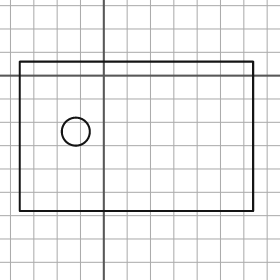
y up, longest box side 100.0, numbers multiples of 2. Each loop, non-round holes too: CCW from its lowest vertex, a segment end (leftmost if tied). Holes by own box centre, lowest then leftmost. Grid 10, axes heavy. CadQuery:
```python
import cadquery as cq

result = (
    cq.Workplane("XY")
    .moveTo(-36.0, -58.0)
    .lineTo(64.0, -58.0)
    .lineTo(64.0, 6.0)
    .lineTo(-36.0, 6.0)
    .close()
    .moveTo(-12.0, -24.0)
    .circle(6.0)
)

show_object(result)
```